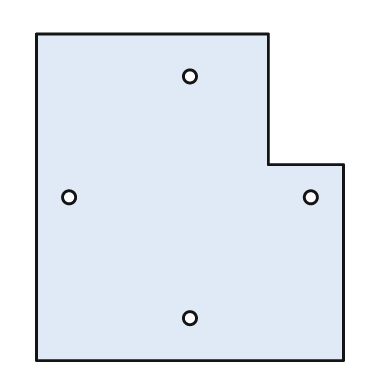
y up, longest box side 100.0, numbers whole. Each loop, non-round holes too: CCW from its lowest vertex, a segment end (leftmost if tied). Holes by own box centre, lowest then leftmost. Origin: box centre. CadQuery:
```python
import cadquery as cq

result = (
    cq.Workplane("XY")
    .moveTo(-47.0, -50.0)
    .lineTo(47.0, -50.0)
    .lineTo(47.0, 10.0)
    .lineTo(24.0, 10.0)
    .lineTo(24.0, 50.0)
    .lineTo(-47.0, 50.0)
    .close()
    .moveTo(0.0, -37.0)
    .circle(2.0)
    .moveTo(-37.0, 0.0)
    .circle(2.0)
    .moveTo(37.0, 0.0)
    .circle(2.0)
    .moveTo(0.0, 37.0)
    .circle(2.0)
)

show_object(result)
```